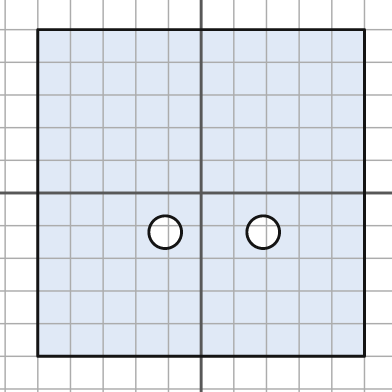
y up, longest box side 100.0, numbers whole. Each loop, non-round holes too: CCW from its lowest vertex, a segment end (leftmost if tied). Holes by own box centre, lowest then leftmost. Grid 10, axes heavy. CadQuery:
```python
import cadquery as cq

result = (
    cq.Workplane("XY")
    .moveTo(-50.0, -50.0)
    .lineTo(50.0, -50.0)
    .lineTo(50.0, 50.0)
    .lineTo(-50.0, 50.0)
    .close()
    .moveTo(-11.0, -12.0)
    .circle(5.0)
    .moveTo(19.0, -12.0)
    .circle(5.0)
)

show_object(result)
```